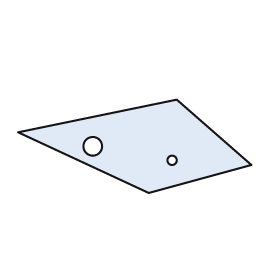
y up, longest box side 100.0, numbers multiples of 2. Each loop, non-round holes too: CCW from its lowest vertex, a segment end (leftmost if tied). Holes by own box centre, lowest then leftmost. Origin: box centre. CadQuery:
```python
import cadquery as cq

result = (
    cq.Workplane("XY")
    .moveTo(6.0, -20.0)
    .lineTo(50.0, -8.0)
    .lineTo(18.0, 20.0)
    .lineTo(-50.0, 6.0)
    .close()
    .moveTo(16.0, -6.0)
    .circle(2.0)
    .moveTo(-18.0, 0.0)
    .circle(4.0)
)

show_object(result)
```